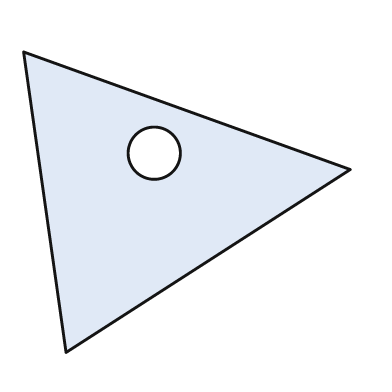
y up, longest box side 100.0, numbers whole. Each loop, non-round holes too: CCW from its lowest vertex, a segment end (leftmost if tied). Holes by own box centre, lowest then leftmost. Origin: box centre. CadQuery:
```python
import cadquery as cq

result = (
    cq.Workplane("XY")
    .moveTo(-37.0, -46.0)
    .lineTo(50.0, 10.0)
    .lineTo(-50.0, 46.0)
    .close()
    .moveTo(-10.0, 15.0)
    .circle(8.0)
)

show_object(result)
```